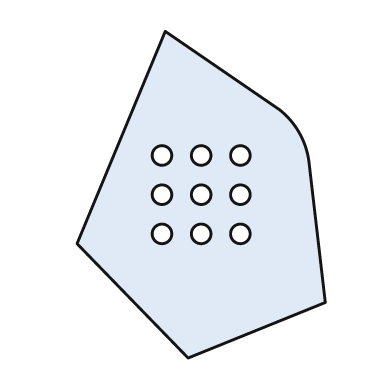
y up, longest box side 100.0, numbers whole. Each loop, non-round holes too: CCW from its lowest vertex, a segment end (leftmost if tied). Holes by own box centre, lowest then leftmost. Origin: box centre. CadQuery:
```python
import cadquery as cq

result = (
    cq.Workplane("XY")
    .moveTo(-4.0, -50.0)
    .lineTo(38.0, -33.0)
    .lineTo(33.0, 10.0)
    .threePointArc((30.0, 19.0), (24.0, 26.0))
    .lineTo(-11.0, 50.0)
    .lineTo(-38.0, -15.0)
    .close()
    .moveTo(-12.0, -12.0)
    .circle(3.0)
    .moveTo(0.0, -12.0)
    .circle(3.0)
    .moveTo(12.0, -12.0)
    .circle(3.0)
    .moveTo(-12.0, 0.0)
    .circle(3.0)
    .moveTo(0.0, 0.0)
    .circle(3.0)
    .moveTo(12.0, 0.0)
    .circle(3.0)
    .moveTo(-12.0, 12.0)
    .circle(3.0)
    .moveTo(0.0, 12.0)
    .circle(3.0)
    .moveTo(12.0, 12.0)
    .circle(3.0)
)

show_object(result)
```